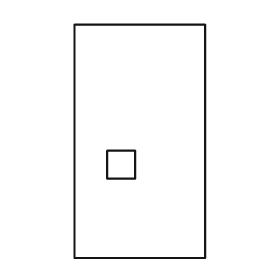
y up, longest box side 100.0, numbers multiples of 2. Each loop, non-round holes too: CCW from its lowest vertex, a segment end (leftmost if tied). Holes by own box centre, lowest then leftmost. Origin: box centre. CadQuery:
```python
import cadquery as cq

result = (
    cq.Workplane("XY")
    .moveTo(-28.0, -50.0)
    .lineTo(28.0, -50.0)
    .lineTo(28.0, 50.0)
    .lineTo(-28.0, 50.0)
    .close()
    .moveTo(-14.0, -16.0)
    .lineTo(-2.0, -16.0)
    .lineTo(-2.0, -4.0)
    .lineTo(-14.0, -4.0)
    .close()
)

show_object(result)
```